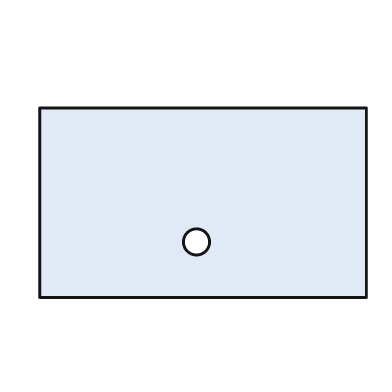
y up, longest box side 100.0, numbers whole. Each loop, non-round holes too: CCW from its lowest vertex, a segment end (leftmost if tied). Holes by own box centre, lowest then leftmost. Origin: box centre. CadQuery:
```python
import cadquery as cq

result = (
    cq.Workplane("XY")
    .moveTo(-50.0, -29.0)
    .lineTo(50.0, -29.0)
    .lineTo(50.0, 29.0)
    .lineTo(-50.0, 29.0)
    .close()
    .moveTo(-2.0, -12.0)
    .circle(4.0)
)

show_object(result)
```